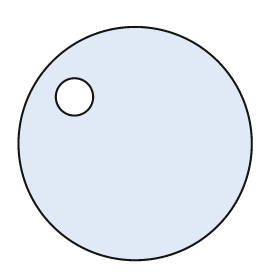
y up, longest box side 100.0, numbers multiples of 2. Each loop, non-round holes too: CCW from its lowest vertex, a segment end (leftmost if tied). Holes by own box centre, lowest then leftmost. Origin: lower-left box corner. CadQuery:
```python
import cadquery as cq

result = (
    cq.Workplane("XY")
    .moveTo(50.0, 50.0)
    .circle(50.0)
    .moveTo(24.0, 70.0)
    .circle(8.0)
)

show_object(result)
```